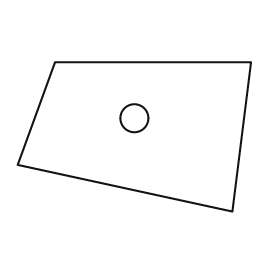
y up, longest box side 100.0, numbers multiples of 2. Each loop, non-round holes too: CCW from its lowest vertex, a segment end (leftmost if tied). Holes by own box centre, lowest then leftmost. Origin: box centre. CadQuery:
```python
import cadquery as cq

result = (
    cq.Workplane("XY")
    .moveTo(42.0, -32.0)
    .lineTo(50.0, 32.0)
    .lineTo(-34.0, 32.0)
    .lineTo(-50.0, -12.0)
    .close()
    .moveTo(0.0, 8.0)
    .circle(6.0)
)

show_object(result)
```